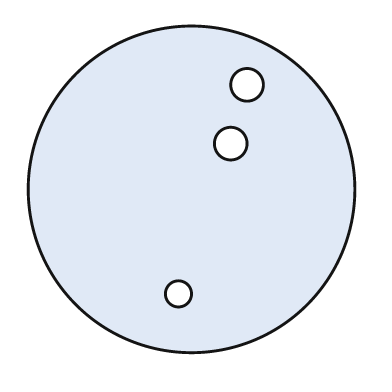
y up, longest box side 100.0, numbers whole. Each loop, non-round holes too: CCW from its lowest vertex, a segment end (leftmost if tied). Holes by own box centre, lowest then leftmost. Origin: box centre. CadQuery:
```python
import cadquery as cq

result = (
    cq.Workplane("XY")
    .moveTo(0.0, 0.0)
    .circle(50.0)
    .moveTo(-4.0, -32.0)
    .circle(4.0)
    .moveTo(12.0, 14.0)
    .circle(5.0)
    .moveTo(17.0, 32.0)
    .circle(5.0)
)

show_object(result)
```